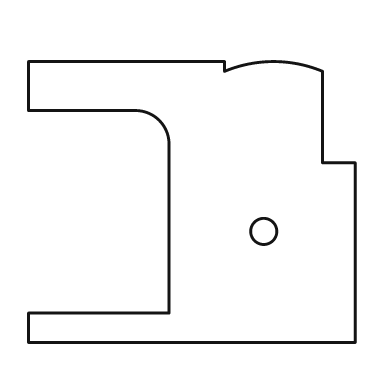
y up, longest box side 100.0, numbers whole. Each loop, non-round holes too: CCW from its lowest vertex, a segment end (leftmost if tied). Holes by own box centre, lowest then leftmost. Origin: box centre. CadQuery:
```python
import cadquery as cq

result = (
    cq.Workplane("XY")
    .moveTo(-50.0, -43.0)
    .lineTo(50.0, -43.0)
    .lineTo(50.0, 12.0)
    .lineTo(40.0, 12.0)
    .lineTo(40.0, 40.0)
    .threePointArc((25.0, 43.0), (10.0, 40.0))
    .lineTo(10.0, 43.0)
    .lineTo(-50.0, 43.0)
    .lineTo(-50.0, 28.0)
    .lineTo(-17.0, 28.0)
    .threePointArc((-10.0, 25.0), (-7.0, 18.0))
    .lineTo(-7.0, -34.0)
    .lineTo(-50.0, -34.0)
    .close()
    .moveTo(22.0, -9.0)
    .circle(4.0)
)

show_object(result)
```